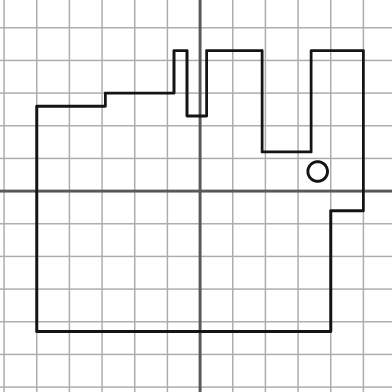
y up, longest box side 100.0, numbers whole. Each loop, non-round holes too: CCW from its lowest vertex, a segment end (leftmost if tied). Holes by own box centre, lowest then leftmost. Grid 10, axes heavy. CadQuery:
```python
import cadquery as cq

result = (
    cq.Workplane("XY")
    .moveTo(-50.0, -43.0)
    .lineTo(40.0, -43.0)
    .lineTo(40.0, -6.0)
    .lineTo(50.0, -6.0)
    .lineTo(50.0, 43.0)
    .lineTo(34.0, 43.0)
    .lineTo(34.0, 12.0)
    .lineTo(19.0, 12.0)
    .lineTo(19.0, 43.0)
    .lineTo(2.0, 43.0)
    .lineTo(2.0, 23.0)
    .lineTo(-4.0, 23.0)
    .lineTo(-4.0, 43.0)
    .lineTo(-8.0, 43.0)
    .lineTo(-8.0, 30.0)
    .lineTo(-29.0, 30.0)
    .lineTo(-29.0, 26.0)
    .lineTo(-50.0, 26.0)
    .close()
    .moveTo(36.0, 6.0)
    .circle(3.0)
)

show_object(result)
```